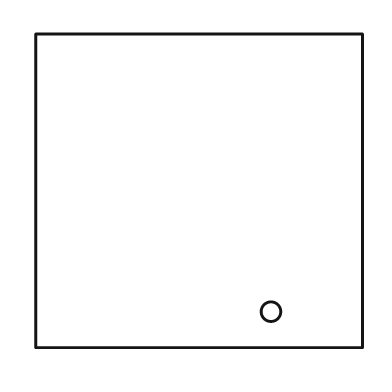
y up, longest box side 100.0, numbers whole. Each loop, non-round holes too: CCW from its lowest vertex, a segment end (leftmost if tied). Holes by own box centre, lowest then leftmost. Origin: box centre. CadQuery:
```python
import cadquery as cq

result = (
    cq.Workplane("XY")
    .moveTo(-50.0, -48.0)
    .lineTo(50.0, -48.0)
    .lineTo(50.0, 48.0)
    .lineTo(-50.0, 48.0)
    .close()
    .moveTo(22.0, -37.0)
    .circle(3.0)
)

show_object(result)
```